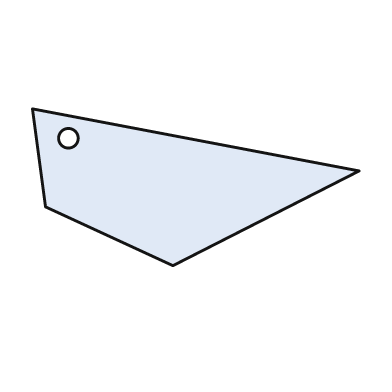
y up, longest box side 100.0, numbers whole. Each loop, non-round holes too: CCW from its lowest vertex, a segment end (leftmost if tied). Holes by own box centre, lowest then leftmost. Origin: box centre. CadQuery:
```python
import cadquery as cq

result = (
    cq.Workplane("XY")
    .moveTo(-7.0, -24.0)
    .lineTo(50.0, 5.0)
    .lineTo(-50.0, 24.0)
    .lineTo(-46.0, -6.0)
    .close()
    .moveTo(-39.0, 15.0)
    .circle(3.0)
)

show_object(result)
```